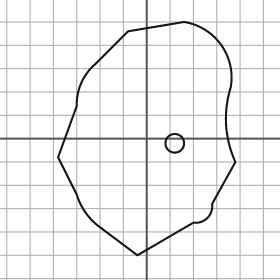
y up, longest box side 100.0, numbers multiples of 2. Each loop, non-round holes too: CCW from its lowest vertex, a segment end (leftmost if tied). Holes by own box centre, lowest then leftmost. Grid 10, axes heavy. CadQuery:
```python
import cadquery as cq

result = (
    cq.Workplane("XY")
    .moveTo(-4.0, -50.0)
    .lineTo(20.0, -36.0)
    .threePointArc((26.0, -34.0), (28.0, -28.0))
    .lineTo(38.0, -10.0)
    .threePointArc((34.0, 6.0), (36.0, 22.0))
    .threePointArc((32.0, 40.0), (16.0, 50.0))
    .lineTo(-8.0, 46.0)
    .lineTo(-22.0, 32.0)
    .threePointArc((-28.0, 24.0), (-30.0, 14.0))
    .lineTo(-38.0, -8.0)
    .lineTo(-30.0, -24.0)
    .threePointArc((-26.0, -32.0), (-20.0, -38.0))
    .close()
    .moveTo(12.0, -2.0)
    .circle(4.0)
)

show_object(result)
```